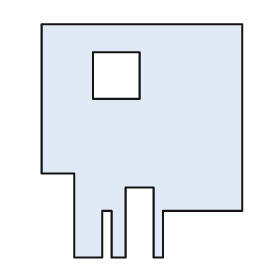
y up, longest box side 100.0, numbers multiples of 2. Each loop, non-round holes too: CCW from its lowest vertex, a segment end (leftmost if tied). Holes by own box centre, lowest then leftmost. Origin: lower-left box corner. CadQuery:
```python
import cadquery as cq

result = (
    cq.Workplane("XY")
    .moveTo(14.0, 0.0)
    .lineTo(26.0, 0.0)
    .lineTo(26.0, 20.0)
    .lineTo(30.0, 20.0)
    .lineTo(30.0, 0.0)
    .lineTo(36.0, 0.0)
    .lineTo(36.0, 30.0)
    .lineTo(48.0, 30.0)
    .lineTo(48.0, 0.0)
    .lineTo(52.0, 0.0)
    .lineTo(52.0, 20.0)
    .lineTo(86.0, 20.0)
    .lineTo(86.0, 100.0)
    .lineTo(0.0, 100.0)
    .lineTo(0.0, 36.0)
    .lineTo(14.0, 36.0)
    .close()
    .moveTo(22.0, 68.0)
    .lineTo(42.0, 68.0)
    .lineTo(42.0, 88.0)
    .lineTo(22.0, 88.0)
    .close()
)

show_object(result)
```